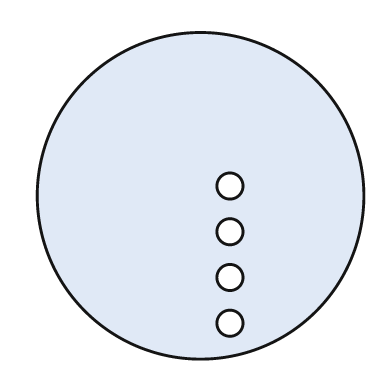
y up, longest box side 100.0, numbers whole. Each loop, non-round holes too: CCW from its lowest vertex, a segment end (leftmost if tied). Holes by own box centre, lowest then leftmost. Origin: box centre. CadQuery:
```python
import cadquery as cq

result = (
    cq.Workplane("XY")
    .moveTo(0.0, 0.0)
    .circle(50.0)
    .moveTo(9.0, -39.0)
    .circle(4.0)
    .moveTo(9.0, -25.0)
    .circle(4.0)
    .moveTo(9.0, -11.0)
    .circle(4.0)
    .moveTo(9.0, 3.0)
    .circle(4.0)
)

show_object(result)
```